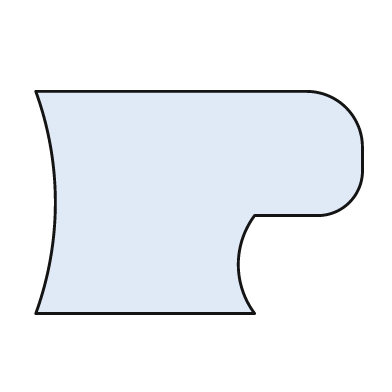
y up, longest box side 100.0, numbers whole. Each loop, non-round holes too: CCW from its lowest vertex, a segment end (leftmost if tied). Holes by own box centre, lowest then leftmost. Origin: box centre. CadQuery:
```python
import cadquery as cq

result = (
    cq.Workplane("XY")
    .moveTo(-50.0, -34.0)
    .lineTo(17.0, -34.0)
    .threePointArc((12.0, -19.0), (17.0, -4.0))
    .lineTo(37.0, -4.0)
    .threePointArc((46.0, 0.0), (50.0, 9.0))
    .lineTo(50.0, 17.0)
    .threePointArc((45.0, 29.0), (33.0, 34.0))
    .lineTo(-50.0, 34.0)
    .threePointArc((-44.0, 0.0), (-50.0, -34.0))
    .close()
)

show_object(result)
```